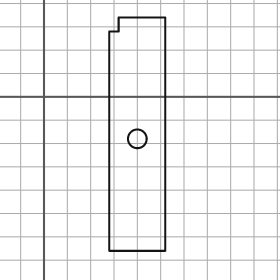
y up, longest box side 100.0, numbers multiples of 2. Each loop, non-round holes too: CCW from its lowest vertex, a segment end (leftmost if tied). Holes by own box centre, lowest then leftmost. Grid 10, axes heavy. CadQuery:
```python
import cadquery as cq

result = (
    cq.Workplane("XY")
    .moveTo(28.0, -66.0)
    .lineTo(52.0, -66.0)
    .lineTo(52.0, 34.0)
    .lineTo(32.0, 34.0)
    .lineTo(32.0, 28.0)
    .lineTo(28.0, 28.0)
    .close()
    .moveTo(40.0, -18.0)
    .circle(4.0)
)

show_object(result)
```